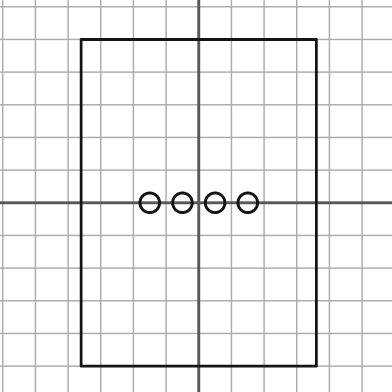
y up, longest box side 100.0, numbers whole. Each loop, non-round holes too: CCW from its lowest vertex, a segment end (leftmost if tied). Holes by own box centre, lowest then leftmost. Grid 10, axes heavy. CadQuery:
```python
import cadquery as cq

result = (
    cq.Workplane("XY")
    .moveTo(-36.0, -50.0)
    .lineTo(36.0, -50.0)
    .lineTo(36.0, 50.0)
    .lineTo(-36.0, 50.0)
    .close()
    .moveTo(-15.0, 0.0)
    .circle(3.0)
    .moveTo(-5.0, 0.0)
    .circle(3.0)
    .moveTo(5.0, 0.0)
    .circle(3.0)
    .moveTo(15.0, 0.0)
    .circle(3.0)
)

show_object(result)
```